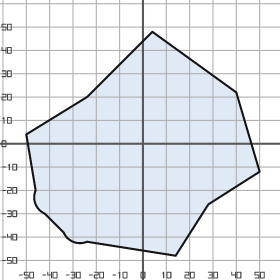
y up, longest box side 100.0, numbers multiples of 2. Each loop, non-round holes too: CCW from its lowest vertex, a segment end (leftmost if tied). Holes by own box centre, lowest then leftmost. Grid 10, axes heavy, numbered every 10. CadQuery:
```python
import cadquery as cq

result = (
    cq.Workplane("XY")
    .moveTo(14.0, -48.0)
    .lineTo(28.0, -26.0)
    .lineTo(50.0, -12.0)
    .lineTo(40.0, 22.0)
    .lineTo(4.0, 48.0)
    .lineTo(-24.0, 20.0)
    .lineTo(-50.0, 4.0)
    .lineTo(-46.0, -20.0)
    .threePointArc((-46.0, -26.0), (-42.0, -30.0))
    .lineTo(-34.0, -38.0)
    .threePointArc((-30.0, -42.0), (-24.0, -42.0))
    .close()
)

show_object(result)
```